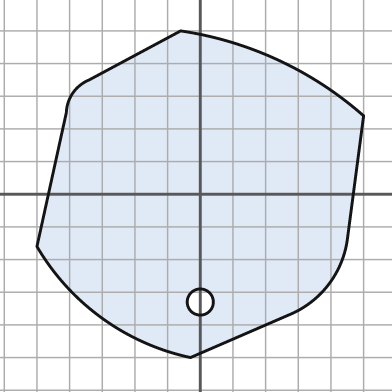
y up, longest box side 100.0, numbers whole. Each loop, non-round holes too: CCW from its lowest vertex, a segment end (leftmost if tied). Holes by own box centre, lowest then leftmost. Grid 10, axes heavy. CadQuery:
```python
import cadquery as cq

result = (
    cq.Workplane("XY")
    .moveTo(-3.0, -50.0)
    .lineTo(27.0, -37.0)
    .threePointArc((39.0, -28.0), (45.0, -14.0))
    .lineTo(50.0, 24.0)
    .threePointArc((24.0, 41.0), (-6.0, 50.0))
    .lineTo(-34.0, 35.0)
    .threePointArc((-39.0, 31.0), (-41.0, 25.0))
    .lineTo(-50.0, -16.0)
    .threePointArc((-30.0, -38.0), (-3.0, -50.0))
    .close()
    .moveTo(0.0, -33.0)
    .circle(4.0)
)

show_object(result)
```